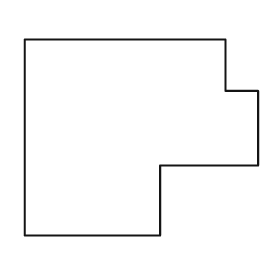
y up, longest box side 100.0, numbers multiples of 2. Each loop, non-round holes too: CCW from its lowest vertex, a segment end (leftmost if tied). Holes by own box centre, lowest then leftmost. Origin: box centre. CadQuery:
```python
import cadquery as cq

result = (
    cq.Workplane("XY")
    .moveTo(-50.0, -42.0)
    .lineTo(8.0, -42.0)
    .lineTo(8.0, -12.0)
    .lineTo(50.0, -12.0)
    .lineTo(50.0, 20.0)
    .lineTo(36.0, 20.0)
    .lineTo(36.0, 42.0)
    .lineTo(-50.0, 42.0)
    .close()
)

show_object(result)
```